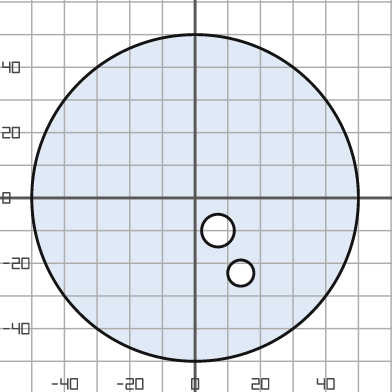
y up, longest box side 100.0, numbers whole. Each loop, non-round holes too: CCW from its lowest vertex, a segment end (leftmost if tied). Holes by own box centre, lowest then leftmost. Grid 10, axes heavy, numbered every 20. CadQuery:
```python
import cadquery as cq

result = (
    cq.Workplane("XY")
    .moveTo(0.0, 0.0)
    .circle(50.0)
    .moveTo(14.0, -23.0)
    .circle(4.0)
    .moveTo(7.0, -10.0)
    .circle(5.0)
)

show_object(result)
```